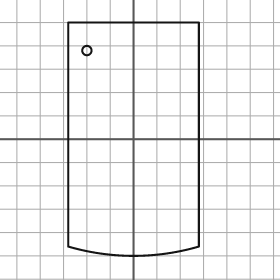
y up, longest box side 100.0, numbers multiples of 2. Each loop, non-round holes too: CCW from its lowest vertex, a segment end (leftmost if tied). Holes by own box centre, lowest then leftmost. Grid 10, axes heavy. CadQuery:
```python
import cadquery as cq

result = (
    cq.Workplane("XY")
    .moveTo(-28.0, -46.0)
    .threePointArc((0.0, -50.0), (28.0, -46.0))
    .lineTo(28.0, 50.0)
    .lineTo(-28.0, 50.0)
    .close()
    .moveTo(-20.0, 38.0)
    .circle(2.0)
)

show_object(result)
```